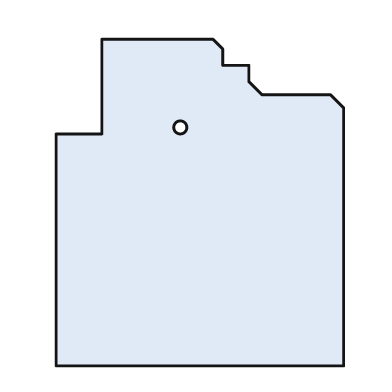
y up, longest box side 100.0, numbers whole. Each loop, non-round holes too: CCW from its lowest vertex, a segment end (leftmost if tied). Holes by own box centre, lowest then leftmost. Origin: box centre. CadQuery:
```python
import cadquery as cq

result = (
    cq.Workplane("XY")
    .moveTo(-44.0, -50.0)
    .lineTo(44.0, -50.0)
    .lineTo(44.0, 29.0)
    .lineTo(40.0, 33.0)
    .lineTo(19.0, 33.0)
    .lineTo(15.0, 37.0)
    .lineTo(15.0, 42.0)
    .lineTo(7.0, 42.0)
    .lineTo(7.0, 47.0)
    .lineTo(4.0, 50.0)
    .lineTo(-30.0, 50.0)
    .lineTo(-30.0, 21.0)
    .lineTo(-44.0, 21.0)
    .close()
    .moveTo(-6.0, 23.0)
    .circle(2.0)
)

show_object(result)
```